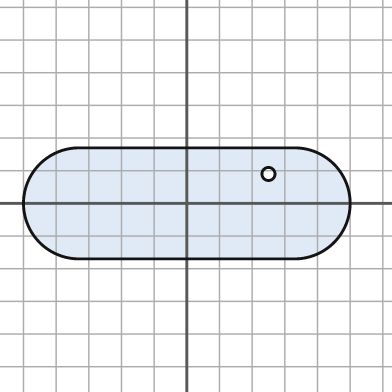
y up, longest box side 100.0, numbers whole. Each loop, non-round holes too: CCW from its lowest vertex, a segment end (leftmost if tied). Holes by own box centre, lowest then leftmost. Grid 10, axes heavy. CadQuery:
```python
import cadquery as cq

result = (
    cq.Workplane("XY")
    .moveTo(-33.0, -17.0)
    .lineTo(33.0, -17.0)
    .threePointArc((50.0, 0.0), (33.0, 17.0))
    .lineTo(-33.0, 17.0)
    .threePointArc((-50.0, 0.0), (-33.0, -17.0))
    .close()
    .moveTo(25.0, 9.0)
    .circle(2.0)
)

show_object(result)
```